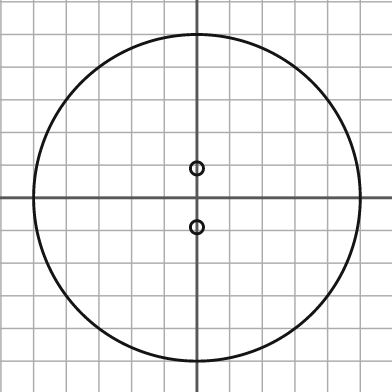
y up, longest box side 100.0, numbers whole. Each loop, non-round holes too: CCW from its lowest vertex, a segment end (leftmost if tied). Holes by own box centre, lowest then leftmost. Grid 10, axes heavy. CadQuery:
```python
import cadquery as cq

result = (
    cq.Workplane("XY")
    .moveTo(0.0, 0.0)
    .circle(50.0)
    .moveTo(0.0, -9.0)
    .circle(2.0)
    .moveTo(0.0, 9.0)
    .circle(2.0)
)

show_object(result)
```